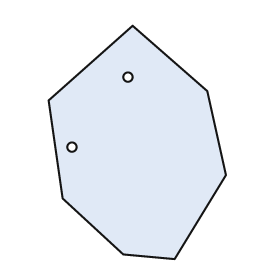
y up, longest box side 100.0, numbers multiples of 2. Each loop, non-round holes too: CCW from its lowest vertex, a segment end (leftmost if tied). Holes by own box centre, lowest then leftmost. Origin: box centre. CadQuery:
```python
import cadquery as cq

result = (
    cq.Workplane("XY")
    .moveTo(16.0, -50.0)
    .lineTo(38.0, -14.0)
    .lineTo(30.0, 22.0)
    .lineTo(-2.0, 50.0)
    .lineTo(-38.0, 18.0)
    .lineTo(-32.0, -24.0)
    .lineTo(-6.0, -48.0)
    .close()
    .moveTo(-28.0, -2.0)
    .circle(2.0)
    .moveTo(-4.0, 28.0)
    .circle(2.0)
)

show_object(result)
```